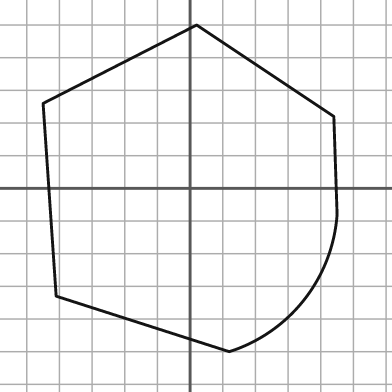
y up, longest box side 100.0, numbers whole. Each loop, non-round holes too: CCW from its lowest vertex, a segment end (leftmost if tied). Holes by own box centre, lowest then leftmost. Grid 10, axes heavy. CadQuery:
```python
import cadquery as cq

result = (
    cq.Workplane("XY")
    .moveTo(12.0, -50.0)
    .threePointArc((35.0, -34.0), (45.0, -8.0))
    .lineTo(44.0, 22.0)
    .lineTo(2.0, 50.0)
    .lineTo(-45.0, 26.0)
    .lineTo(-41.0, -33.0)
    .close()
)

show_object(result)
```